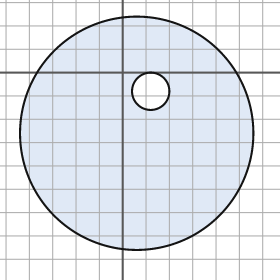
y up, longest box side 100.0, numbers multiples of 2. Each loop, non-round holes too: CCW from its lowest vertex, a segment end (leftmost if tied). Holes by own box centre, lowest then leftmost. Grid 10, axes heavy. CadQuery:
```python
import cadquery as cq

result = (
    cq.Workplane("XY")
    .moveTo(6.0, -26.0)
    .circle(50.0)
    .moveTo(12.0, -8.0)
    .circle(8.0)
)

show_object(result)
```